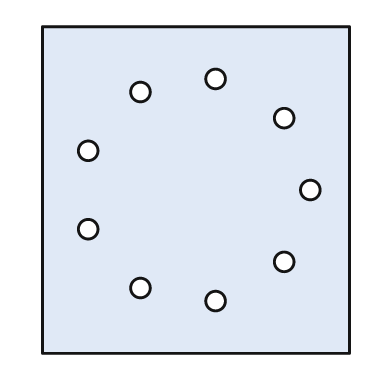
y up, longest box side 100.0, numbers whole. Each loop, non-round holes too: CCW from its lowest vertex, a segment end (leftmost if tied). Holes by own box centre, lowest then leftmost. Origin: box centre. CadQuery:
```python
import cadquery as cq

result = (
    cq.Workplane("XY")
    .moveTo(-47.0, -50.0)
    .lineTo(47.0, -50.0)
    .lineTo(47.0, 50.0)
    .lineTo(-47.0, 50.0)
    .close()
    .moveTo(6.0, -34.0)
    .circle(3.0)
    .moveTo(-17.0, -30.0)
    .circle(3.0)
    .moveTo(27.0, -22.0)
    .circle(3.0)
    .moveTo(-33.0, -12.0)
    .circle(3.0)
    .moveTo(35.0, 0.0)
    .circle(3.0)
    .moveTo(-33.0, 12.0)
    .circle(3.0)
    .moveTo(27.0, 22.0)
    .circle(3.0)
    .moveTo(-17.0, 30.0)
    .circle(3.0)
    .moveTo(6.0, 34.0)
    .circle(3.0)
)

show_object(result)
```